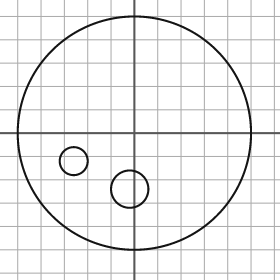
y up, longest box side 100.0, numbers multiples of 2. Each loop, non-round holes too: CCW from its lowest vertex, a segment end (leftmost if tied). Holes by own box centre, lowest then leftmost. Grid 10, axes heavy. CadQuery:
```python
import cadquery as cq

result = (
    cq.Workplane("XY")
    .moveTo(0.0, 0.0)
    .circle(50.0)
    .moveTo(-2.0, -24.0)
    .circle(8.0)
    .moveTo(-26.0, -12.0)
    .circle(6.0)
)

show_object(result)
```